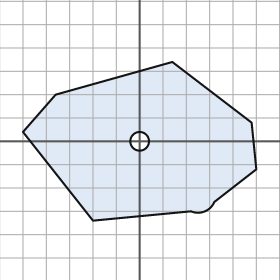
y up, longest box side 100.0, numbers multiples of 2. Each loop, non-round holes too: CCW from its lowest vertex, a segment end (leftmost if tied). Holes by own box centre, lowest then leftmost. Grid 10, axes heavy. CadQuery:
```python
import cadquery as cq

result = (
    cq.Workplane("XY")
    .moveTo(-20.0, -34.0)
    .lineTo(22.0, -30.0)
    .threePointArc((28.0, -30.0), (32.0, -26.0))
    .lineTo(50.0, -12.0)
    .lineTo(48.0, 8.0)
    .lineTo(14.0, 34.0)
    .lineTo(-36.0, 20.0)
    .lineTo(-50.0, 4.0)
    .close()
    .moveTo(0.0, 0.0)
    .circle(4.0)
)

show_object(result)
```